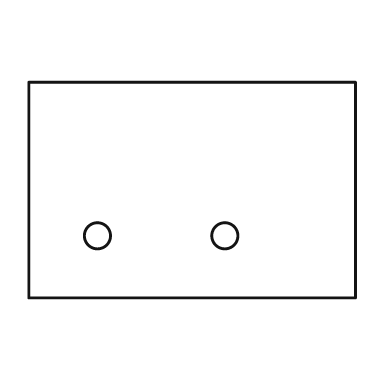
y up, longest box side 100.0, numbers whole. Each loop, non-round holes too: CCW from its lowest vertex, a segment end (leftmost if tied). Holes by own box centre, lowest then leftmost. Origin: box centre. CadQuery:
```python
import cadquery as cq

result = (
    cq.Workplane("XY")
    .moveTo(-50.0, -33.0)
    .lineTo(50.0, -33.0)
    .lineTo(50.0, 33.0)
    .lineTo(-50.0, 33.0)
    .close()
    .moveTo(-29.0, -14.0)
    .circle(4.0)
    .moveTo(10.0, -14.0)
    .circle(4.0)
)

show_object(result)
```